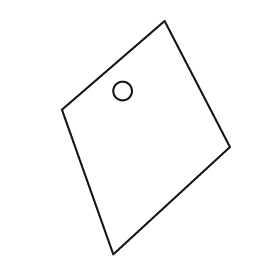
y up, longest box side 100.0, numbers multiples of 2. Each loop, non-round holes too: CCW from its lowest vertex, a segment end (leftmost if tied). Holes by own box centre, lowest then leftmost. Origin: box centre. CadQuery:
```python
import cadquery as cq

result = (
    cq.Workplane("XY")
    .moveTo(-14.0, -50.0)
    .lineTo(36.0, -4.0)
    .lineTo(8.0, 50.0)
    .lineTo(-36.0, 12.0)
    .close()
    .moveTo(-10.0, 20.0)
    .circle(4.0)
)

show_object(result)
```